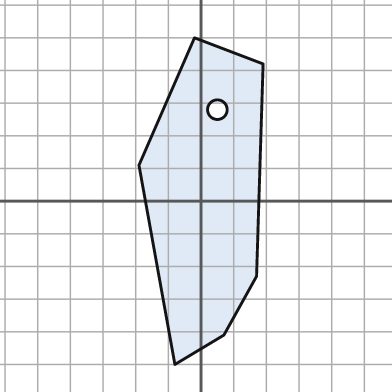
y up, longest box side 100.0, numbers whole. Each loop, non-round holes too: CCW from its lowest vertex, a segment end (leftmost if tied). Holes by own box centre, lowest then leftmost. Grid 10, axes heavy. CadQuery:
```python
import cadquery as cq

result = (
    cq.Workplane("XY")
    .moveTo(-8.0, -50.0)
    .lineTo(7.0, -41.0)
    .lineTo(17.0, -23.0)
    .lineTo(19.0, 42.0)
    .lineTo(-2.0, 50.0)
    .lineTo(-19.0, 11.0)
    .close()
    .moveTo(5.0, 28.0)
    .circle(3.0)
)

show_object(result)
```